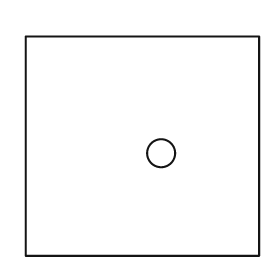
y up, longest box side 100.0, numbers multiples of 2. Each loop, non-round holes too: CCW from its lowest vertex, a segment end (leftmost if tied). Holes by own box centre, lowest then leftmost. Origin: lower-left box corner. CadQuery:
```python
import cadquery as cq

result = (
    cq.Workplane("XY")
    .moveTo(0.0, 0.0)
    .lineTo(100.0, 0.0)
    .lineTo(100.0, 94.0)
    .lineTo(0.0, 94.0)
    .close()
    .moveTo(58.0, 44.0)
    .circle(6.0)
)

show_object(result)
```